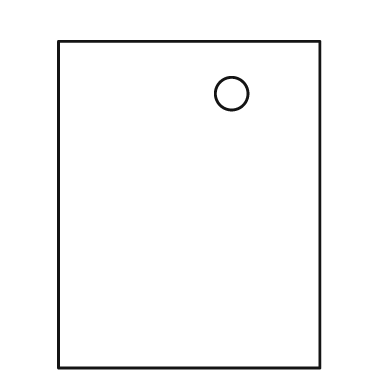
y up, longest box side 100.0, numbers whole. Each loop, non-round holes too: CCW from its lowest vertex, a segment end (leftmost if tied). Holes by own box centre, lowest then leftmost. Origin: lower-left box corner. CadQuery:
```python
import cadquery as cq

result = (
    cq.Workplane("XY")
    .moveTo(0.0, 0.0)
    .lineTo(80.0, 0.0)
    .lineTo(80.0, 100.0)
    .lineTo(0.0, 100.0)
    .close()
    .moveTo(53.0, 84.0)
    .circle(5.0)
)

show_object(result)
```